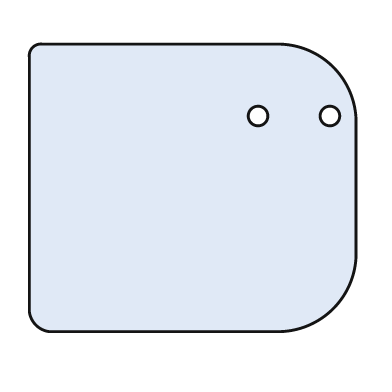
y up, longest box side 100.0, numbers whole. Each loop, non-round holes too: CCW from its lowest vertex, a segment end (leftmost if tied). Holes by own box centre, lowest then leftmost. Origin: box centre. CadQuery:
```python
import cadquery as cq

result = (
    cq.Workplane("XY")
    .moveTo(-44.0, -44.0)
    .lineTo(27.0, -44.0)
    .threePointArc((43.0, -37.0), (50.0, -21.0))
    .lineTo(50.0, 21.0)
    .threePointArc((43.0, 37.0), (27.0, 44.0))
    .lineTo(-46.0, 44.0)
    .threePointArc((-49.0, 43.0), (-50.0, 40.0))
    .lineTo(-50.0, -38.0)
    .threePointArc((-48.0, -42.0), (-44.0, -44.0))
    .close()
    .moveTo(20.0, 22.0)
    .circle(3.0)
    .moveTo(42.0, 22.0)
    .circle(3.0)
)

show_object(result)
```